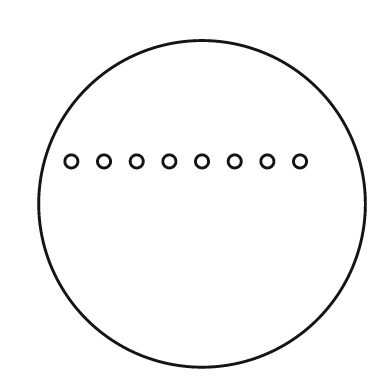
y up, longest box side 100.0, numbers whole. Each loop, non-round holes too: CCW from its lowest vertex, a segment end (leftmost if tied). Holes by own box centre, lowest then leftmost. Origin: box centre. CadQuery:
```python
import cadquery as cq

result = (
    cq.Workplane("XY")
    .moveTo(0.0, 0.0)
    .circle(50.0)
    .moveTo(-40.0, 13.0)
    .circle(2.0)
    .moveTo(-30.0, 13.0)
    .circle(2.0)
    .moveTo(-20.0, 13.0)
    .circle(2.0)
    .moveTo(-10.0, 13.0)
    .circle(2.0)
    .moveTo(0.0, 13.0)
    .circle(2.0)
    .moveTo(10.0, 13.0)
    .circle(2.0)
    .moveTo(20.0, 13.0)
    .circle(2.0)
    .moveTo(30.0, 13.0)
    .circle(2.0)
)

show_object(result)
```